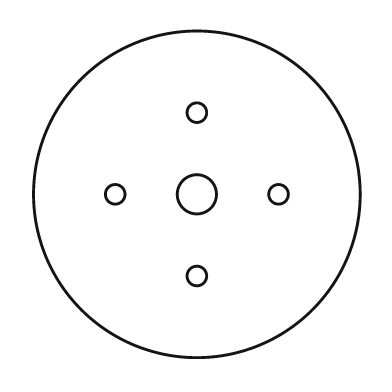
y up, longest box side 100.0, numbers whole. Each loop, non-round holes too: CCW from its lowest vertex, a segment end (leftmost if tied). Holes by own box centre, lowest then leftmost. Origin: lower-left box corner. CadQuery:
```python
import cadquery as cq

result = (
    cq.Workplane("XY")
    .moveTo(50.0, 50.0)
    .circle(50.0)
    .moveTo(50.0, 25.0)
    .circle(3.0)
    .moveTo(25.0, 50.0)
    .circle(3.0)
    .moveTo(50.0, 50.0)
    .circle(6.0)
    .moveTo(75.0, 50.0)
    .circle(3.0)
    .moveTo(50.0, 75.0)
    .circle(3.0)
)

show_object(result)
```